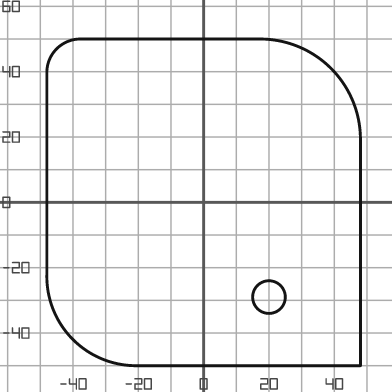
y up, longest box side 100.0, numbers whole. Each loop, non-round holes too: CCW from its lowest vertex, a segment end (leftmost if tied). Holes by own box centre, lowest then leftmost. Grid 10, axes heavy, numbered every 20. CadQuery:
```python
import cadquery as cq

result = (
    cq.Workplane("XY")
    .moveTo(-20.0, -50.0)
    .lineTo(48.0, -50.0)
    .lineTo(48.0, 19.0)
    .threePointArc((39.0, 41.0), (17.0, 50.0))
    .lineTo(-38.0, 50.0)
    .threePointArc((-45.0, 47.0), (-48.0, 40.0))
    .lineTo(-48.0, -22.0)
    .threePointArc((-40.0, -42.0), (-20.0, -50.0))
    .close()
    .moveTo(20.0, -29.0)
    .circle(5.0)
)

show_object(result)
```